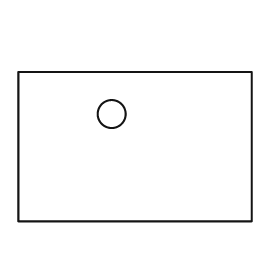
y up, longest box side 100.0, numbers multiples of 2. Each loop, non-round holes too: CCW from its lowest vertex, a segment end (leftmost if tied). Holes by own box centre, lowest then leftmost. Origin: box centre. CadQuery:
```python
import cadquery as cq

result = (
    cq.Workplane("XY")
    .moveTo(-50.0, -32.0)
    .lineTo(50.0, -32.0)
    .lineTo(50.0, 32.0)
    .lineTo(-50.0, 32.0)
    .close()
    .moveTo(-10.0, 14.0)
    .circle(6.0)
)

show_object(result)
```